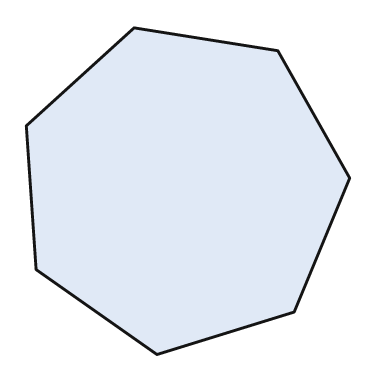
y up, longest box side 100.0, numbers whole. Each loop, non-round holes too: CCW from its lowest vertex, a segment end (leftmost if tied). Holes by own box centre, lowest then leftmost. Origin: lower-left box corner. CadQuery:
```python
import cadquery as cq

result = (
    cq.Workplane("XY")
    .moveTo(40.0, 0.0)
    .lineTo(82.0, 13.0)
    .lineTo(99.0, 54.0)
    .lineTo(77.0, 93.0)
    .lineTo(33.0, 100.0)
    .lineTo(0.0, 70.0)
    .lineTo(3.0, 26.0)
    .close()
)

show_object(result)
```